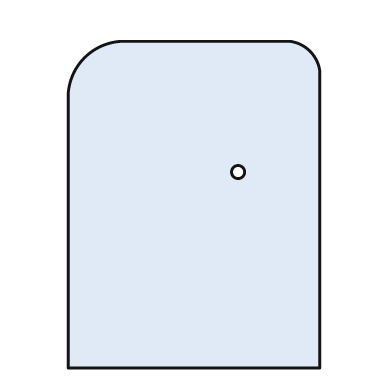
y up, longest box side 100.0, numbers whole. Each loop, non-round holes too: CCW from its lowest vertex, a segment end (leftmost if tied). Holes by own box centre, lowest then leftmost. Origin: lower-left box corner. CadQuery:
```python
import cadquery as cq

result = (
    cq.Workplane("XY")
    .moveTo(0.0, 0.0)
    .lineTo(77.0, 0.0)
    .lineTo(77.0, 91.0)
    .threePointArc((74.0, 97.0), (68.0, 100.0))
    .lineTo(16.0, 100.0)
    .threePointArc((5.0, 95.0), (0.0, 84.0))
    .close()
    .moveTo(52.0, 60.0)
    .circle(2.0)
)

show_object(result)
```